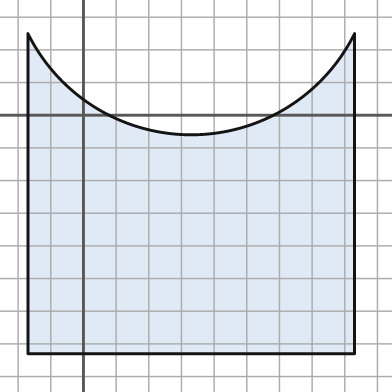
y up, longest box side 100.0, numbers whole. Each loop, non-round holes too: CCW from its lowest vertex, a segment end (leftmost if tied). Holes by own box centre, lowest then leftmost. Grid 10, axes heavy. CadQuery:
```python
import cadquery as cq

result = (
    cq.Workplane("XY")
    .moveTo(-17.0, -73.0)
    .lineTo(83.0, -73.0)
    .lineTo(83.0, 25.0)
    .threePointArc((33.0, -6.0), (-17.0, 25.0))
    .close()
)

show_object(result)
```